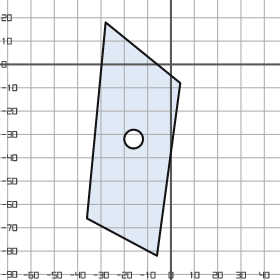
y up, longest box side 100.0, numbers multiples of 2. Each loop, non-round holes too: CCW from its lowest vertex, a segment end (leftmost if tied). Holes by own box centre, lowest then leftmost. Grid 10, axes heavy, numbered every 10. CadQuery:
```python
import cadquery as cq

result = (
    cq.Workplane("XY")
    .moveTo(-6.0, -82.0)
    .lineTo(4.0, -8.0)
    .lineTo(-28.0, 18.0)
    .lineTo(-36.0, -66.0)
    .close()
    .moveTo(-16.0, -32.0)
    .circle(4.0)
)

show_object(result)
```